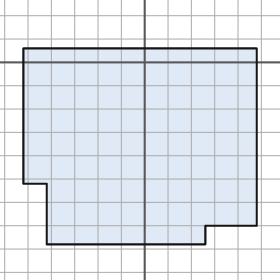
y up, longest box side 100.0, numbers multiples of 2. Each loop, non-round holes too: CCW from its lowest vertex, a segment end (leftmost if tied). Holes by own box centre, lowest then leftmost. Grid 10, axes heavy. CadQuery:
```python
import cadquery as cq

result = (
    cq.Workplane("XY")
    .moveTo(-42.0, -78.0)
    .lineTo(26.0, -78.0)
    .lineTo(26.0, -70.0)
    .lineTo(48.0, -70.0)
    .lineTo(48.0, 6.0)
    .lineTo(-52.0, 6.0)
    .lineTo(-52.0, -52.0)
    .lineTo(-42.0, -52.0)
    .close()
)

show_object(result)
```